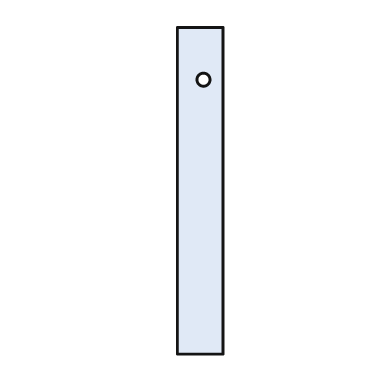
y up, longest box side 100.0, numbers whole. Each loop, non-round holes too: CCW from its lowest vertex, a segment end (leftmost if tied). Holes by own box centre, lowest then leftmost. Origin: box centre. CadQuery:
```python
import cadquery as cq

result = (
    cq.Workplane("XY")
    .moveTo(-7.0, -50.0)
    .lineTo(7.0, -50.0)
    .lineTo(7.0, 50.0)
    .lineTo(-7.0, 50.0)
    .close()
    .moveTo(1.0, 34.0)
    .circle(2.0)
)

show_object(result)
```